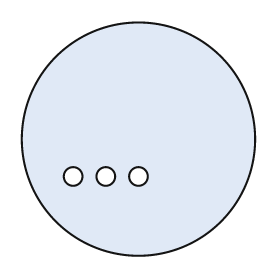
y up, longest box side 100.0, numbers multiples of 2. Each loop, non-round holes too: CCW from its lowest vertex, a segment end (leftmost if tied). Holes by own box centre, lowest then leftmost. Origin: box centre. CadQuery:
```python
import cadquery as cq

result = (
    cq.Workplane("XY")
    .moveTo(0.0, 0.0)
    .circle(50.0)
    .moveTo(-28.0, -16.0)
    .circle(4.0)
    .moveTo(-14.0, -16.0)
    .circle(4.0)
    .moveTo(0.0, -16.0)
    .circle(4.0)
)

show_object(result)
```